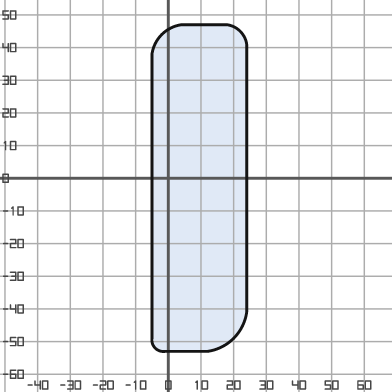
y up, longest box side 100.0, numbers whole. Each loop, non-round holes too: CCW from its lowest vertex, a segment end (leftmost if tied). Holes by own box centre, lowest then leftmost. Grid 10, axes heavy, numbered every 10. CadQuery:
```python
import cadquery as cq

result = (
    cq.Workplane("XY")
    .moveTo(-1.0, -53.0)
    .lineTo(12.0, -53.0)
    .threePointArc((20.0, -49.0), (24.0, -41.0))
    .lineTo(24.0, 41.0)
    .threePointArc((22.0, 45.0), (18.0, 47.0))
    .lineTo(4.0, 47.0)
    .threePointArc((-2.0, 44.0), (-5.0, 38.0))
    .lineTo(-5.0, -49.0)
    .threePointArc((-4.0, -52.0), (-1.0, -53.0))
    .close()
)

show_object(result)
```